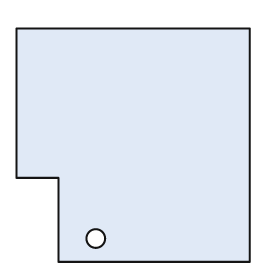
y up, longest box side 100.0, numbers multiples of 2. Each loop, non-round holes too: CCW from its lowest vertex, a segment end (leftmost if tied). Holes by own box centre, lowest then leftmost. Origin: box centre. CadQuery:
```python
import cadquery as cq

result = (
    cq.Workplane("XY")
    .moveTo(-32.0, -50.0)
    .lineTo(50.0, -50.0)
    .lineTo(50.0, 50.0)
    .lineTo(-50.0, 50.0)
    .lineTo(-50.0, -14.0)
    .lineTo(-32.0, -14.0)
    .close()
    .moveTo(-16.0, -40.0)
    .circle(4.0)
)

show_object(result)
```